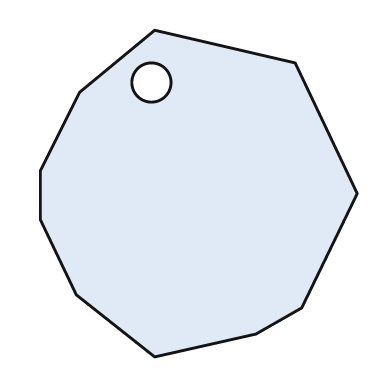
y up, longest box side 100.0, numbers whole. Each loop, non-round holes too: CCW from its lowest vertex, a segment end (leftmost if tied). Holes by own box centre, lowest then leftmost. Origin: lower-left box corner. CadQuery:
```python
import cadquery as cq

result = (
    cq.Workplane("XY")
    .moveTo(35.0, 0.0)
    .lineTo(66.0, 7.0)
    .lineTo(80.0, 15.0)
    .lineTo(97.0, 50.0)
    .lineTo(78.0, 90.0)
    .lineTo(35.0, 100.0)
    .lineTo(12.0, 81.0)
    .lineTo(0.0, 57.0)
    .lineTo(0.0, 42.0)
    .lineTo(11.0, 19.0)
    .close()
    .moveTo(34.0, 84.0)
    .circle(6.0)
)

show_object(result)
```